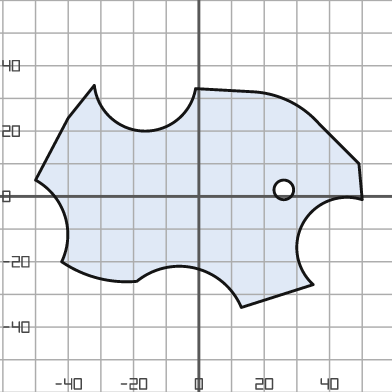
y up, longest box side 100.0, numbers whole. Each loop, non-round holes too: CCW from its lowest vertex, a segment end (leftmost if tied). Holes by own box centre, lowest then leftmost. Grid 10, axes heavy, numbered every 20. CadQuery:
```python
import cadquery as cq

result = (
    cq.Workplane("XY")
    .moveTo(13.0, -34.0)
    .lineTo(35.0, -27.0)
    .threePointArc((32.0, -8.0), (50.0, -1.0))
    .lineTo(49.0, 10.0)
    .lineTo(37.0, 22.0)
    .threePointArc((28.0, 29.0), (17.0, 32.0))
    .lineTo(-1.0, 33.0)
    .threePointArc((-17.0, 20.0), (-32.0, 34.0))
    .lineTo(-40.0, 24.0)
    .lineTo(-50.0, 5.0)
    .threePointArc((-41.0, -6.0), (-42.0, -20.0))
    .threePointArc((-31.0, -25.0), (-19.0, -26.0))
    .threePointArc((-1.0, -22.0), (13.0, -34.0))
    .close()
    .moveTo(26.0, 2.0)
    .circle(3.0)
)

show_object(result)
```